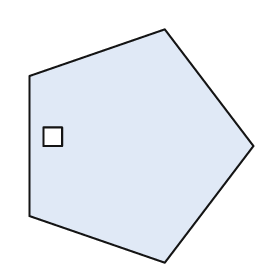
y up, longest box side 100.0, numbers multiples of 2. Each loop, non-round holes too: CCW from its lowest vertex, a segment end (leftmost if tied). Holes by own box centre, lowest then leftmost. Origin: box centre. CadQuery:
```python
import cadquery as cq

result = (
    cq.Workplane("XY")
    .moveTo(10.0, -50.0)
    .lineTo(48.0, 0.0)
    .lineTo(10.0, 50.0)
    .lineTo(-48.0, 30.0)
    .lineTo(-48.0, -30.0)
    .close()
    .moveTo(-42.0, 0.0)
    .lineTo(-34.0, 0.0)
    .lineTo(-34.0, 8.0)
    .lineTo(-42.0, 8.0)
    .close()
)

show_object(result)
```